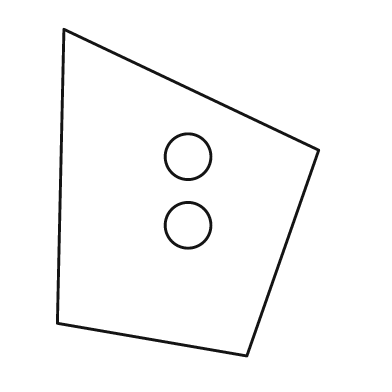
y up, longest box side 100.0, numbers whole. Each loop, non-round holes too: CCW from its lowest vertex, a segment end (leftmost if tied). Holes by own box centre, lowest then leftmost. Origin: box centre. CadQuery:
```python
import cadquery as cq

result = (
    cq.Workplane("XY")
    .moveTo(18.0, -50.0)
    .lineTo(40.0, 13.0)
    .lineTo(-38.0, 50.0)
    .lineTo(-40.0, -40.0)
    .close()
    .moveTo(0.0, -10.0)
    .circle(7.0)
    .moveTo(0.0, 11.0)
    .circle(7.0)
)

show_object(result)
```